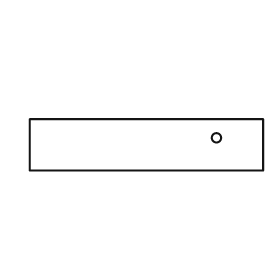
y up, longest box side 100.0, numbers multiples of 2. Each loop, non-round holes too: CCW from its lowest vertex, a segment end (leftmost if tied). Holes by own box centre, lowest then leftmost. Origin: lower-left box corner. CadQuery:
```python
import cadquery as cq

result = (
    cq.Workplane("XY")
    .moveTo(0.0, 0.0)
    .lineTo(100.0, 0.0)
    .lineTo(100.0, 22.0)
    .lineTo(0.0, 22.0)
    .close()
    .moveTo(80.0, 14.0)
    .circle(2.0)
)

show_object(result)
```